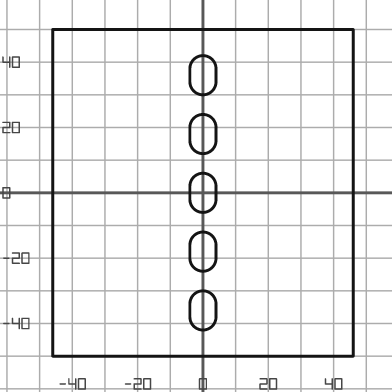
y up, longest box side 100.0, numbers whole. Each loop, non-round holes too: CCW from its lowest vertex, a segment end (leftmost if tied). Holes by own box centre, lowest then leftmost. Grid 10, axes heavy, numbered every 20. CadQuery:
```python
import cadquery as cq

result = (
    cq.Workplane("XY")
    .moveTo(-46.0, -50.0)
    .lineTo(46.0, -50.0)
    .lineTo(46.0, 50.0)
    .lineTo(-46.0, 50.0)
    .close()
    .moveTo(-4.0, -38.0)
    .threePointArc((0.0, -42.0), (4.0, -38.0))
    .lineTo(4.0, -34.0)
    .threePointArc((0.0, -30.0), (-4.0, -34.0))
    .close()
    .moveTo(-4.0, -20.0)
    .threePointArc((0.0, -24.0), (4.0, -20.0))
    .lineTo(4.0, -16.0)
    .threePointArc((0.0, -12.0), (-4.0, -16.0))
    .close()
    .moveTo(-4.0, -2.0)
    .threePointArc((0.0, -6.0), (4.0, -2.0))
    .lineTo(4.0, 2.0)
    .threePointArc((0.0, 6.0), (-4.0, 2.0))
    .close()
    .moveTo(-4.0, 16.0)
    .threePointArc((0.0, 12.0), (4.0, 16.0))
    .lineTo(4.0, 20.0)
    .threePointArc((0.0, 24.0), (-4.0, 20.0))
    .close()
    .moveTo(-4.0, 34.0)
    .threePointArc((0.0, 30.0), (4.0, 34.0))
    .lineTo(4.0, 38.0)
    .threePointArc((0.0, 42.0), (-4.0, 38.0))
    .close()
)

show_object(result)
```